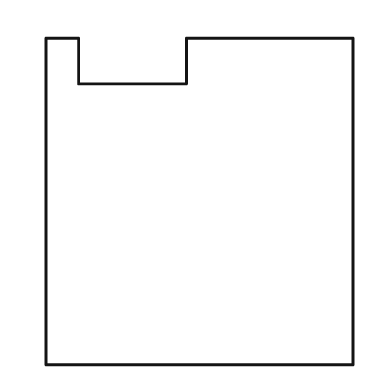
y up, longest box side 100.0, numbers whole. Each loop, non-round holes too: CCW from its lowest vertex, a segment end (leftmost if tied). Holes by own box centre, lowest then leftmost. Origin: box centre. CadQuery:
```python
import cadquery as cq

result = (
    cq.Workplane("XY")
    .moveTo(-47.0, -50.0)
    .lineTo(47.0, -50.0)
    .lineTo(47.0, 50.0)
    .lineTo(-4.0, 50.0)
    .lineTo(-4.0, 36.0)
    .lineTo(-37.0, 36.0)
    .lineTo(-37.0, 50.0)
    .lineTo(-47.0, 50.0)
    .close()
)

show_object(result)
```